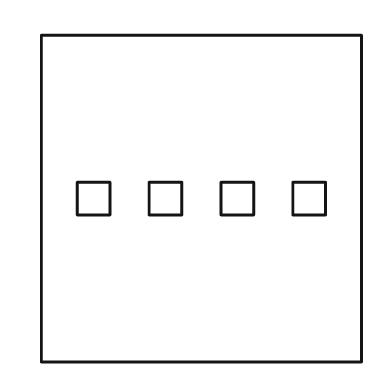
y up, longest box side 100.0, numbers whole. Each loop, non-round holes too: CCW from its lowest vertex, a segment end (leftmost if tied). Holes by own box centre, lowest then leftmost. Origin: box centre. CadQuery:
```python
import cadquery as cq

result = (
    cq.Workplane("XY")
    .moveTo(-49.0, -50.0)
    .lineTo(49.0, -50.0)
    .lineTo(49.0, 50.0)
    .lineTo(-49.0, 50.0)
    .close()
    .moveTo(-38.0, -5.0)
    .lineTo(-28.0, -5.0)
    .lineTo(-28.0, 5.0)
    .lineTo(-38.0, 5.0)
    .close()
    .moveTo(-16.0, -5.0)
    .lineTo(-6.0, -5.0)
    .lineTo(-6.0, 5.0)
    .lineTo(-16.0, 5.0)
    .close()
    .moveTo(6.0, -5.0)
    .lineTo(16.0, -5.0)
    .lineTo(16.0, 5.0)
    .lineTo(6.0, 5.0)
    .close()
    .moveTo(28.0, -5.0)
    .lineTo(38.0, -5.0)
    .lineTo(38.0, 5.0)
    .lineTo(28.0, 5.0)
    .close()
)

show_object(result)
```